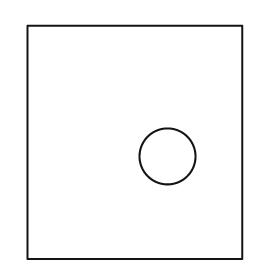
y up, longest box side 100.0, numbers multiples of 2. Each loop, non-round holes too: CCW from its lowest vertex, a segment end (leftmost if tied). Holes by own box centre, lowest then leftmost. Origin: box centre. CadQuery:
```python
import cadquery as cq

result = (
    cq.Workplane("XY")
    .moveTo(-46.0, -50.0)
    .lineTo(46.0, -50.0)
    .lineTo(46.0, 50.0)
    .lineTo(-46.0, 50.0)
    .close()
    .moveTo(14.0, -6.0)
    .circle(12.0)
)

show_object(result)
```